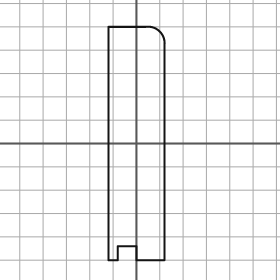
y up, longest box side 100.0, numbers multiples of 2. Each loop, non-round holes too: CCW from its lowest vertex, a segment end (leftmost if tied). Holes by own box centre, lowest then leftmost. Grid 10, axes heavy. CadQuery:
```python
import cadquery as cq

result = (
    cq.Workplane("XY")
    .moveTo(-12.0, -50.0)
    .lineTo(-8.0, -50.0)
    .lineTo(-8.0, -44.0)
    .lineTo(0.0, -44.0)
    .lineTo(0.0, -50.0)
    .lineTo(12.0, -50.0)
    .lineTo(12.0, 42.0)
    .threePointArc((10.0, 48.0), (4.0, 50.0))
    .lineTo(-12.0, 50.0)
    .close()
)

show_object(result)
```